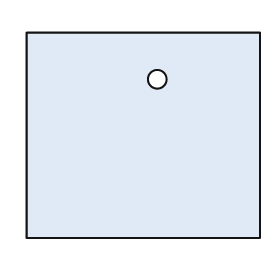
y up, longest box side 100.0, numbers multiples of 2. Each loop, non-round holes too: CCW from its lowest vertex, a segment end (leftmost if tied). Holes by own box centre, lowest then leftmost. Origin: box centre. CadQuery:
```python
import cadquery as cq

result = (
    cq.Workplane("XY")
    .moveTo(-50.0, -44.0)
    .lineTo(50.0, -44.0)
    .lineTo(50.0, 44.0)
    .lineTo(-50.0, 44.0)
    .close()
    .moveTo(6.0, 24.0)
    .circle(4.0)
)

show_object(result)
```